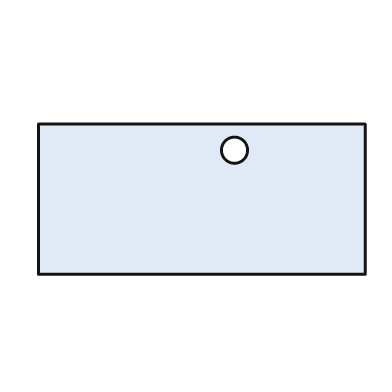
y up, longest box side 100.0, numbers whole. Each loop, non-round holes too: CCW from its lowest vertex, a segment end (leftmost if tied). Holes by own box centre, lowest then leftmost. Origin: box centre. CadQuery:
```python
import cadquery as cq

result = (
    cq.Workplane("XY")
    .moveTo(-50.0, -23.0)
    .lineTo(50.0, -23.0)
    .lineTo(50.0, 23.0)
    .lineTo(-50.0, 23.0)
    .close()
    .moveTo(10.0, 15.0)
    .circle(4.0)
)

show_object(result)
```